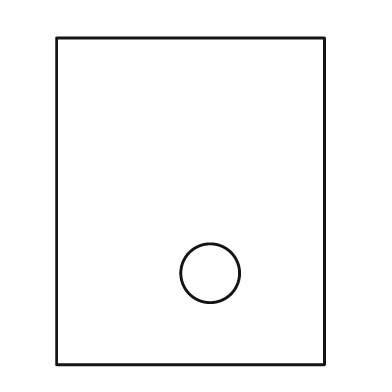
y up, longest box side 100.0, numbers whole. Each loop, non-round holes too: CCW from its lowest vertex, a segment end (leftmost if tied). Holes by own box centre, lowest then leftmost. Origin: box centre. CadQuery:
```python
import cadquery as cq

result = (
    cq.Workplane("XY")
    .moveTo(-41.0, -50.0)
    .lineTo(41.0, -50.0)
    .lineTo(41.0, 50.0)
    .lineTo(-41.0, 50.0)
    .close()
    .moveTo(6.0, -22.0)
    .circle(9.0)
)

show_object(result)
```